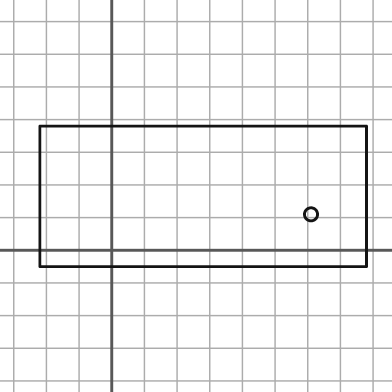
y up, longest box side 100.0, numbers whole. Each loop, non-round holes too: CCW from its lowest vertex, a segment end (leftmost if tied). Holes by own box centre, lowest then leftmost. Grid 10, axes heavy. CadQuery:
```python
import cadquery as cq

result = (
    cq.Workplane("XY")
    .moveTo(-22.0, -5.0)
    .lineTo(78.0, -5.0)
    .lineTo(78.0, 38.0)
    .lineTo(-22.0, 38.0)
    .close()
    .moveTo(61.0, 11.0)
    .circle(2.0)
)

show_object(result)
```